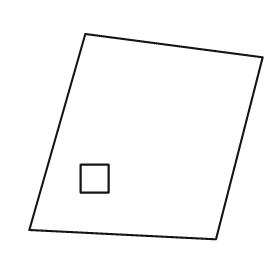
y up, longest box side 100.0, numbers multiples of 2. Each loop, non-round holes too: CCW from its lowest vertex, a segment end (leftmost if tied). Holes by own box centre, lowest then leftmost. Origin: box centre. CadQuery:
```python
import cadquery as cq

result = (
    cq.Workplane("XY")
    .moveTo(30.0, -44.0)
    .lineTo(50.0, 34.0)
    .lineTo(-26.0, 44.0)
    .lineTo(-50.0, -40.0)
    .close()
    .moveTo(-28.0, -24.0)
    .lineTo(-16.0, -24.0)
    .lineTo(-16.0, -12.0)
    .lineTo(-28.0, -12.0)
    .close()
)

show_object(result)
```